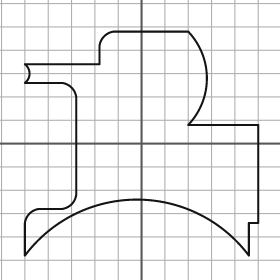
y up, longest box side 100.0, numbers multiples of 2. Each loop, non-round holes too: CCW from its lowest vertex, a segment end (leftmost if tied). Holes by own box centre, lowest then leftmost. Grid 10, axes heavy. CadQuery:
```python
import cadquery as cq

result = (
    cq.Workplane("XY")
    .moveTo(-50.0, -48.0)
    .threePointArc((-2.0, -24.0), (46.0, -48.0))
    .lineTo(46.0, -34.0)
    .lineTo(50.0, -34.0)
    .lineTo(50.0, 8.0)
    .lineTo(20.0, 8.0)
    .threePointArc((28.0, 28.0), (20.0, 48.0))
    .lineTo(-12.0, 48.0)
    .threePointArc((-16.0, 46.0), (-18.0, 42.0))
    .lineTo(-18.0, 34.0)
    .lineTo(-50.0, 34.0)
    .threePointArc((-48.0, 30.0), (-50.0, 26.0))
    .lineTo(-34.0, 26.0)
    .threePointArc((-30.0, 24.0), (-28.0, 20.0))
    .lineTo(-28.0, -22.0)
    .threePointArc((-30.0, -26.0), (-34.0, -28.0))
    .lineTo(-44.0, -28.0)
    .threePointArc((-48.0, -30.0), (-50.0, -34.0))
    .close()
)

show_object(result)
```